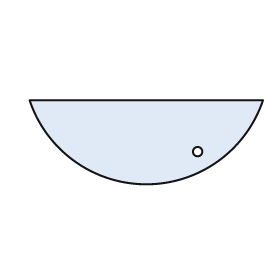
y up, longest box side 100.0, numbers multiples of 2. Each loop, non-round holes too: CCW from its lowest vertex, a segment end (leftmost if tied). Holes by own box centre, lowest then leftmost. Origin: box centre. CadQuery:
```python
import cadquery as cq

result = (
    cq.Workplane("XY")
    .moveTo(-50.0, 18.0)
    .threePointArc((0.0, -18.0), (50.0, 18.0))
    .close()
    .moveTo(22.0, -4.0)
    .circle(2.0)
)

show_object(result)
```